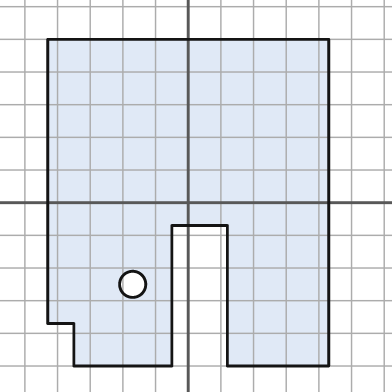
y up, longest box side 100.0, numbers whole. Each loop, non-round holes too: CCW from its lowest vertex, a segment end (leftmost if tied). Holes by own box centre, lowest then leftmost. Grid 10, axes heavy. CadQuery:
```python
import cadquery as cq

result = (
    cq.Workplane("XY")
    .moveTo(-35.0, -50.0)
    .lineTo(-5.0, -50.0)
    .lineTo(-5.0, -7.0)
    .lineTo(12.0, -7.0)
    .lineTo(12.0, -50.0)
    .lineTo(43.0, -50.0)
    .lineTo(43.0, 50.0)
    .lineTo(-43.0, 50.0)
    .lineTo(-43.0, -37.0)
    .lineTo(-35.0, -37.0)
    .close()
    .moveTo(-17.0, -25.0)
    .circle(4.0)
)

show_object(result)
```